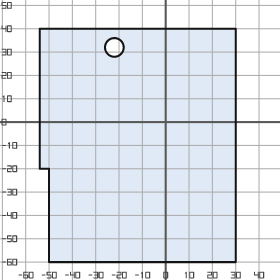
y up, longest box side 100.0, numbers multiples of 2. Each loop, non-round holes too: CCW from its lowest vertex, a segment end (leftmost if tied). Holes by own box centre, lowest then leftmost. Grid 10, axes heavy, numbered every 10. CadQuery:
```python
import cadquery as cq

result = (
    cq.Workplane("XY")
    .moveTo(-50.0, -60.0)
    .lineTo(30.0, -60.0)
    .lineTo(30.0, 40.0)
    .lineTo(-54.0, 40.0)
    .lineTo(-54.0, -20.0)
    .lineTo(-50.0, -20.0)
    .close()
    .moveTo(-22.0, 32.0)
    .circle(4.0)
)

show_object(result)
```